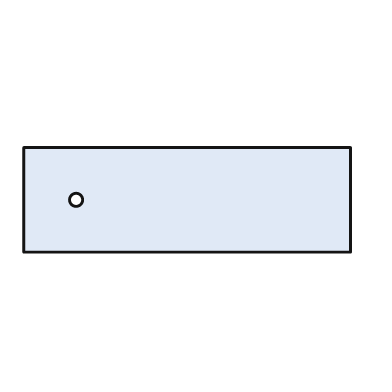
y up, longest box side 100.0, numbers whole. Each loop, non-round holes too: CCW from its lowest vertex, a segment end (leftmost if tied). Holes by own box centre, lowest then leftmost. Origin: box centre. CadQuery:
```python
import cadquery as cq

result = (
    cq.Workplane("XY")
    .moveTo(-50.0, -16.0)
    .lineTo(50.0, -16.0)
    .lineTo(50.0, 16.0)
    .lineTo(-50.0, 16.0)
    .close()
    .moveTo(-34.0, 0.0)
    .circle(2.0)
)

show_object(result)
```